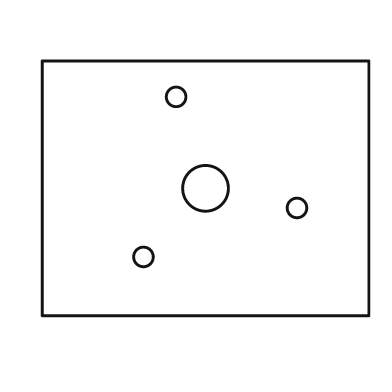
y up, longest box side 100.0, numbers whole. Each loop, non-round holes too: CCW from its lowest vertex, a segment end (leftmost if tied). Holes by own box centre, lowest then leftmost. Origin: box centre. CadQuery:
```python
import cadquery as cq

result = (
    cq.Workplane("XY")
    .moveTo(-50.0, -39.0)
    .lineTo(50.0, -39.0)
    .lineTo(50.0, 39.0)
    .lineTo(-50.0, 39.0)
    .close()
    .moveTo(-19.0, -21.0)
    .circle(3.0)
    .moveTo(28.0, -6.0)
    .circle(3.0)
    .moveTo(0.0, 0.0)
    .circle(7.0)
    .moveTo(-9.0, 28.0)
    .circle(3.0)
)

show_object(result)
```